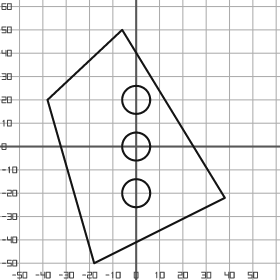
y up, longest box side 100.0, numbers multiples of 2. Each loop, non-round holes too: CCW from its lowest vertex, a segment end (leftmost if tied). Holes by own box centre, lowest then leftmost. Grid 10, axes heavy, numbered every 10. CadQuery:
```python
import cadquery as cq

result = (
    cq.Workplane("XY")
    .moveTo(-18.0, -50.0)
    .lineTo(38.0, -22.0)
    .lineTo(-6.0, 50.0)
    .lineTo(-38.0, 20.0)
    .close()
    .moveTo(0.0, -20.0)
    .circle(6.0)
    .moveTo(0.0, 0.0)
    .circle(6.0)
    .moveTo(0.0, 20.0)
    .circle(6.0)
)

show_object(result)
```